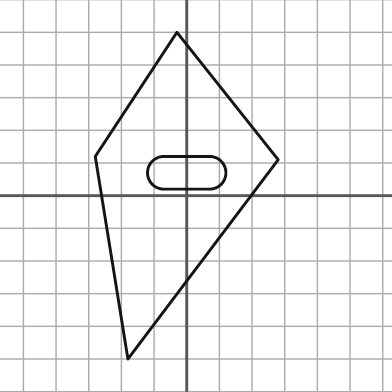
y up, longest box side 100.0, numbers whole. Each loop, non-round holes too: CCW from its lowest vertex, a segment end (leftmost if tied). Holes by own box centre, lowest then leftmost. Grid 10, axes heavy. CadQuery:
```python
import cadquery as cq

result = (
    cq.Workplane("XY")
    .moveTo(-18.0, -50.0)
    .lineTo(28.0, 11.0)
    .lineTo(-3.0, 50.0)
    .lineTo(-28.0, 12.0)
    .close()
    .moveTo(-7.0, 2.0)
    .lineTo(7.0, 2.0)
    .threePointArc((12.0, 7.0), (7.0, 12.0))
    .lineTo(-7.0, 12.0)
    .threePointArc((-12.0, 7.0), (-7.0, 2.0))
    .close()
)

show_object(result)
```